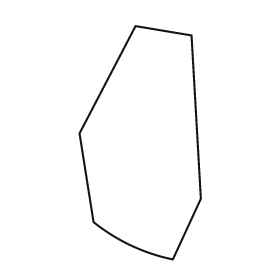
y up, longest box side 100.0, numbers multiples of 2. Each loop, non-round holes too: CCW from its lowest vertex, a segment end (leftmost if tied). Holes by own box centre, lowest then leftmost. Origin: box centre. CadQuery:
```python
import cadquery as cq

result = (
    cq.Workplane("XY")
    .moveTo(14.0, -50.0)
    .lineTo(26.0, -24.0)
    .lineTo(22.0, 46.0)
    .lineTo(-2.0, 50.0)
    .lineTo(-26.0, 4.0)
    .lineTo(-20.0, -34.0)
    .threePointArc((-4.0, -44.0), (14.0, -50.0))
    .close()
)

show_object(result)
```